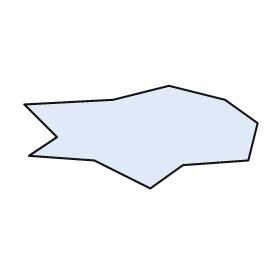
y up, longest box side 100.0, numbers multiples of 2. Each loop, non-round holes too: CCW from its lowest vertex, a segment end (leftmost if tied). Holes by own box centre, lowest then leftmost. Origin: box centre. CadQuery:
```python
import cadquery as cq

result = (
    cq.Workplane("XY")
    .moveTo(4.0, -22.0)
    .lineTo(18.0, -12.0)
    .lineTo(46.0, -10.0)
    .lineTo(50.0, 6.0)
    .lineTo(36.0, 16.0)
    .lineTo(12.0, 22.0)
    .lineTo(-12.0, 16.0)
    .lineTo(-50.0, 14.0)
    .lineTo(-36.0, 0.0)
    .lineTo(-48.0, -8.0)
    .lineTo(-20.0, -10.0)
    .close()
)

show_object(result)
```